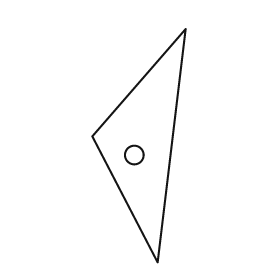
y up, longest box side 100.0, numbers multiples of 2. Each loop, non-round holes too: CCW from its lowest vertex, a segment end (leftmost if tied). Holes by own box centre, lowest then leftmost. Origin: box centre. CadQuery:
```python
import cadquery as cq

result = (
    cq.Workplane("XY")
    .moveTo(8.0, -50.0)
    .lineTo(20.0, 50.0)
    .lineTo(-20.0, 4.0)
    .close()
    .moveTo(-2.0, -4.0)
    .circle(4.0)
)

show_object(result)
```